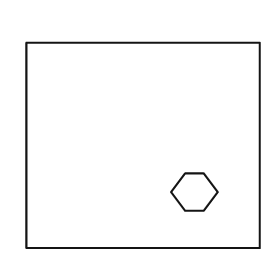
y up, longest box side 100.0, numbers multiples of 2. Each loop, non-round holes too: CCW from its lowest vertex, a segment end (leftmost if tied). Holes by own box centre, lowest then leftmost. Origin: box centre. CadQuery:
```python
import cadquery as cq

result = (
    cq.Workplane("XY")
    .moveTo(-50.0, -44.0)
    .lineTo(50.0, -44.0)
    .lineTo(50.0, 44.0)
    .lineTo(-50.0, 44.0)
    .close()
    .moveTo(18.0, -28.0)
    .lineTo(26.0, -28.0)
    .lineTo(32.0, -20.0)
    .lineTo(26.0, -12.0)
    .lineTo(18.0, -12.0)
    .lineTo(12.0, -20.0)
    .close()
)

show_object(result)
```